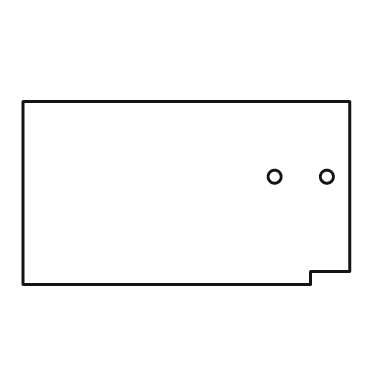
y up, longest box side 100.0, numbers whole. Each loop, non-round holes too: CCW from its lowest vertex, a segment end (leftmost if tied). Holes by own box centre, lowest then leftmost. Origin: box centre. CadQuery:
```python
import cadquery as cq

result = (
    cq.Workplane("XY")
    .moveTo(-50.0, -28.0)
    .lineTo(38.0, -28.0)
    .lineTo(38.0, -24.0)
    .lineTo(50.0, -24.0)
    .lineTo(50.0, 28.0)
    .lineTo(-50.0, 28.0)
    .close()
    .moveTo(27.0, 5.0)
    .circle(2.0)
    .moveTo(43.0, 5.0)
    .circle(2.0)
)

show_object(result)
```